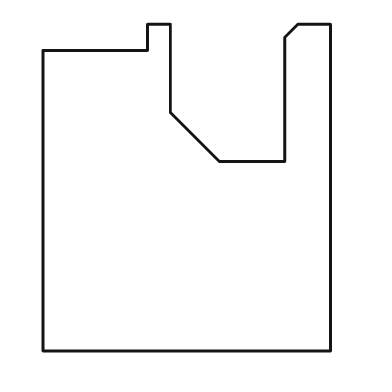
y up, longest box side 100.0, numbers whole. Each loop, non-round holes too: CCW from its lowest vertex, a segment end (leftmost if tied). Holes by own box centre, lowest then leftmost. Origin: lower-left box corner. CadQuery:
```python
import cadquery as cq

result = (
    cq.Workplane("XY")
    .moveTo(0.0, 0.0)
    .lineTo(88.0, 0.0)
    .lineTo(88.0, 100.0)
    .lineTo(78.0, 100.0)
    .lineTo(74.0, 96.0)
    .lineTo(74.0, 58.0)
    .lineTo(54.0, 58.0)
    .lineTo(39.0, 73.0)
    .lineTo(39.0, 100.0)
    .lineTo(32.0, 100.0)
    .lineTo(32.0, 92.0)
    .lineTo(0.0, 92.0)
    .close()
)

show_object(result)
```